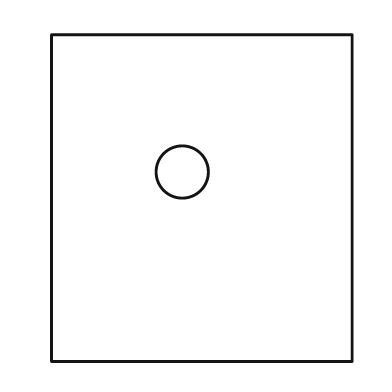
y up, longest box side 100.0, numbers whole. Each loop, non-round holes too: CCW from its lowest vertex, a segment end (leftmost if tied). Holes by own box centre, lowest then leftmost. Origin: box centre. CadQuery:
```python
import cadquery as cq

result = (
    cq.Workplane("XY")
    .moveTo(-46.0, -50.0)
    .lineTo(46.0, -50.0)
    .lineTo(46.0, 50.0)
    .lineTo(-46.0, 50.0)
    .close()
    .moveTo(-6.0, 8.0)
    .circle(8.0)
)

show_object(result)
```